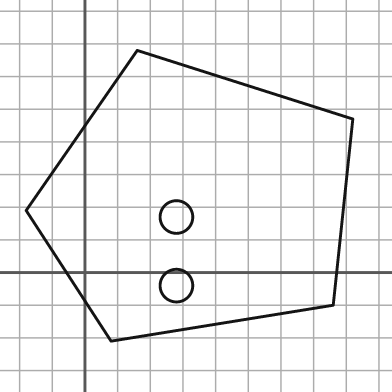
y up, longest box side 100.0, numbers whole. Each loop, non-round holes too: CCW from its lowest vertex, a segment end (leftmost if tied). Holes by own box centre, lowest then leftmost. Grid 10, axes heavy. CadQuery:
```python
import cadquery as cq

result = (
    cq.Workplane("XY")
    .moveTo(8.0, -21.0)
    .lineTo(76.0, -10.0)
    .lineTo(82.0, 47.0)
    .lineTo(16.0, 68.0)
    .lineTo(-18.0, 19.0)
    .close()
    .moveTo(28.0, -4.0)
    .circle(5.0)
    .moveTo(28.0, 17.0)
    .circle(5.0)
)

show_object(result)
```